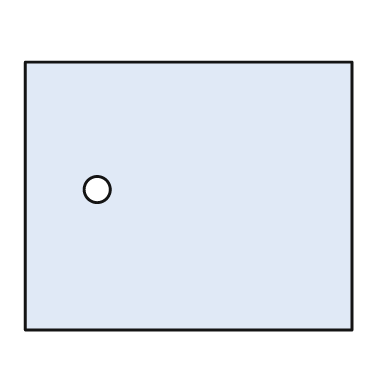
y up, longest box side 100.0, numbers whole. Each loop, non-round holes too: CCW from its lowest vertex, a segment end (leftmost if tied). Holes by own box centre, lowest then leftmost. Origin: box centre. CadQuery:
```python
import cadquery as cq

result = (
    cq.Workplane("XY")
    .moveTo(-50.0, -41.0)
    .lineTo(50.0, -41.0)
    .lineTo(50.0, 41.0)
    .lineTo(-50.0, 41.0)
    .close()
    .moveTo(-28.0, 2.0)
    .circle(4.0)
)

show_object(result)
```